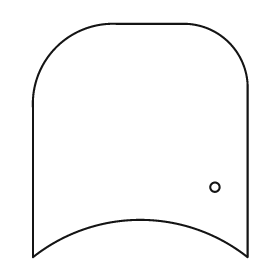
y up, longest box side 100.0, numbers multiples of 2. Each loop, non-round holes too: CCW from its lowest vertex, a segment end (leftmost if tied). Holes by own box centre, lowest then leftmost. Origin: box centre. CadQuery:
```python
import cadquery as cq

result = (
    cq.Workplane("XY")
    .moveTo(-46.0, -50.0)
    .threePointArc((0.0, -34.0), (46.0, -50.0))
    .lineTo(46.0, 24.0)
    .threePointArc((38.0, 42.0), (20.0, 50.0))
    .lineTo(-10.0, 50.0)
    .threePointArc((-36.0, 40.0), (-46.0, 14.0))
    .close()
    .moveTo(32.0, -20.0)
    .circle(2.0)
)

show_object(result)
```